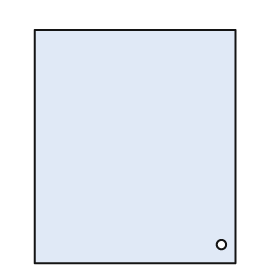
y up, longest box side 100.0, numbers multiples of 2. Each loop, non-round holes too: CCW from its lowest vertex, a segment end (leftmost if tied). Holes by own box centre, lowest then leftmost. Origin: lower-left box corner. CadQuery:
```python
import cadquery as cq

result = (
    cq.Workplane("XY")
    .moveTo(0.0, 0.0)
    .lineTo(86.0, 0.0)
    .lineTo(86.0, 100.0)
    .lineTo(0.0, 100.0)
    .close()
    .moveTo(80.0, 8.0)
    .circle(2.0)
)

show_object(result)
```